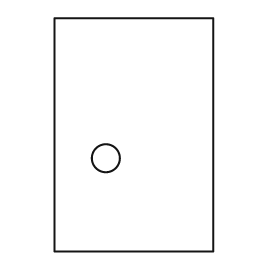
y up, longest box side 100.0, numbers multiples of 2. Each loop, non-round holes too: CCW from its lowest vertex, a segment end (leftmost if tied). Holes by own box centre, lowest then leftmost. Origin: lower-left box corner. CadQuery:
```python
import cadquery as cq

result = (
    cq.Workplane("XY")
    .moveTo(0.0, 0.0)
    .lineTo(68.0, 0.0)
    .lineTo(68.0, 100.0)
    .lineTo(0.0, 100.0)
    .close()
    .moveTo(22.0, 40.0)
    .circle(6.0)
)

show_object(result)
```